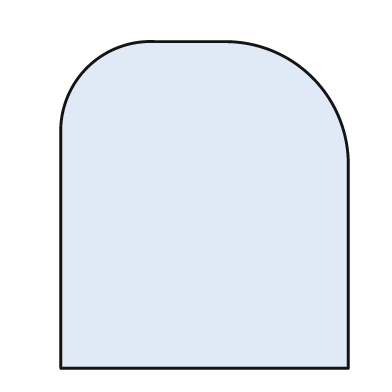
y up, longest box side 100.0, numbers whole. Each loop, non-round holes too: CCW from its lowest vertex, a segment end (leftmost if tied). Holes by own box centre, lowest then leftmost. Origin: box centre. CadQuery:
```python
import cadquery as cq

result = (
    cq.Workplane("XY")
    .moveTo(-44.0, -50.0)
    .lineTo(44.0, -50.0)
    .lineTo(44.0, 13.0)
    .threePointArc((33.0, 39.0), (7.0, 50.0))
    .lineTo(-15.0, 50.0)
    .threePointArc((-36.0, 42.0), (-44.0, 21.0))
    .close()
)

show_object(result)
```